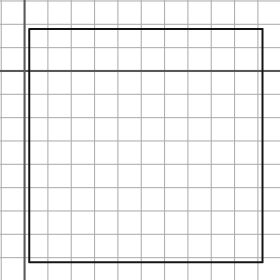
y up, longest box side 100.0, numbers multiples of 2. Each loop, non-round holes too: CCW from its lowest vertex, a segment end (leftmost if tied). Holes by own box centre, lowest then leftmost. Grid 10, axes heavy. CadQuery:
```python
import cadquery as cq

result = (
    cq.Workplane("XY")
    .moveTo(2.0, -82.0)
    .lineTo(102.0, -82.0)
    .lineTo(102.0, 18.0)
    .lineTo(2.0, 18.0)
    .close()
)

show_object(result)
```